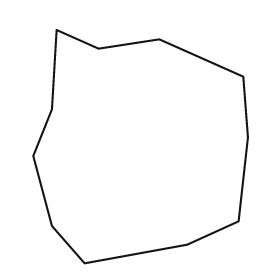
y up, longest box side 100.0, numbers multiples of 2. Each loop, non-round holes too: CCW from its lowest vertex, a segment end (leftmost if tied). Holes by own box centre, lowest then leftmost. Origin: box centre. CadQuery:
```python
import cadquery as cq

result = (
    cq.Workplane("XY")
    .moveTo(-24.0, -50.0)
    .lineTo(20.0, -42.0)
    .lineTo(42.0, -32.0)
    .lineTo(46.0, 4.0)
    .lineTo(44.0, 30.0)
    .lineTo(8.0, 46.0)
    .lineTo(-18.0, 42.0)
    .lineTo(-36.0, 50.0)
    .lineTo(-38.0, 16.0)
    .lineTo(-46.0, -4.0)
    .lineTo(-38.0, -34.0)
    .close()
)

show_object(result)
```